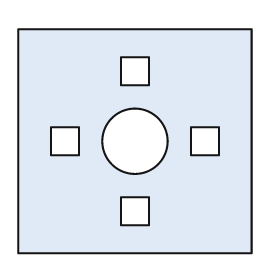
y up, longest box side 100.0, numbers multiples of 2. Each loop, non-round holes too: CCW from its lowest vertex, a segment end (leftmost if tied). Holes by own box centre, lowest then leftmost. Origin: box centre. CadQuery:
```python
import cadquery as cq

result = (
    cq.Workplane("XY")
    .moveTo(-50.0, -48.0)
    .lineTo(50.0, -48.0)
    .lineTo(50.0, 48.0)
    .lineTo(-50.0, 48.0)
    .close()
    .moveTo(-6.0, -36.0)
    .lineTo(6.0, -36.0)
    .lineTo(6.0, -24.0)
    .lineTo(-6.0, -24.0)
    .close()
    .moveTo(-36.0, -6.0)
    .lineTo(-24.0, -6.0)
    .lineTo(-24.0, 6.0)
    .lineTo(-36.0, 6.0)
    .close()
    .moveTo(0.0, 0.0)
    .circle(14.0)
    .moveTo(24.0, -6.0)
    .lineTo(36.0, -6.0)
    .lineTo(36.0, 6.0)
    .lineTo(24.0, 6.0)
    .close()
    .moveTo(-6.0, 24.0)
    .lineTo(6.0, 24.0)
    .lineTo(6.0, 36.0)
    .lineTo(-6.0, 36.0)
    .close()
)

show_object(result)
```